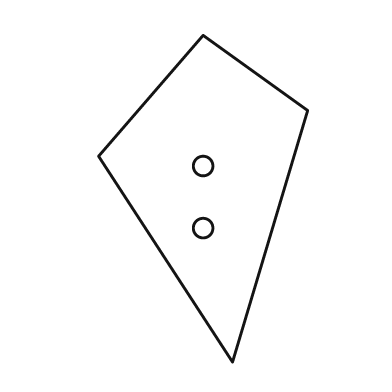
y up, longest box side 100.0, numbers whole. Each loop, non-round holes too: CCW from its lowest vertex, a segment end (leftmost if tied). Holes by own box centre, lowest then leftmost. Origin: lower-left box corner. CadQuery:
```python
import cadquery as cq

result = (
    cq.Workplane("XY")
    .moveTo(41.0, 0.0)
    .lineTo(64.0, 77.0)
    .lineTo(32.0, 100.0)
    .lineTo(0.0, 63.0)
    .close()
    .moveTo(32.0, 41.0)
    .circle(3.0)
    .moveTo(32.0, 60.0)
    .circle(3.0)
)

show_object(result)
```